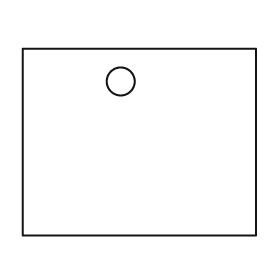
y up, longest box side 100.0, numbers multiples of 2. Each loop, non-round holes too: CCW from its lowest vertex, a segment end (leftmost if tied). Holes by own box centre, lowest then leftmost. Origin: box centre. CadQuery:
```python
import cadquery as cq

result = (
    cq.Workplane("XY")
    .moveTo(-50.0, -40.0)
    .lineTo(50.0, -40.0)
    .lineTo(50.0, 40.0)
    .lineTo(-50.0, 40.0)
    .close()
    .moveTo(-8.0, 26.0)
    .circle(6.0)
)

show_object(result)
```